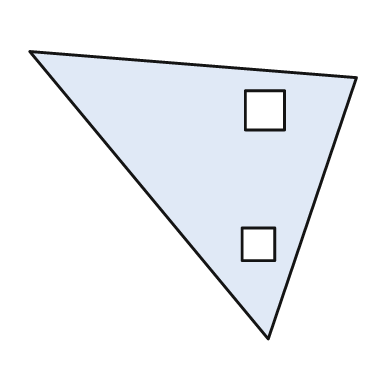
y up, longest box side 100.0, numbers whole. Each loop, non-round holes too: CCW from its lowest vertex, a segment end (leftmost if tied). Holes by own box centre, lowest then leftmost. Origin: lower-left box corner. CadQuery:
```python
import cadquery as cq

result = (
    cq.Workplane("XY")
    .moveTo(73.0, 0.0)
    .lineTo(100.0, 80.0)
    .lineTo(0.0, 88.0)
    .close()
    .moveTo(65.0, 24.0)
    .lineTo(75.0, 24.0)
    .lineTo(75.0, 34.0)
    .lineTo(65.0, 34.0)
    .close()
    .moveTo(66.0, 64.0)
    .lineTo(78.0, 64.0)
    .lineTo(78.0, 76.0)
    .lineTo(66.0, 76.0)
    .close()
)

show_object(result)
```